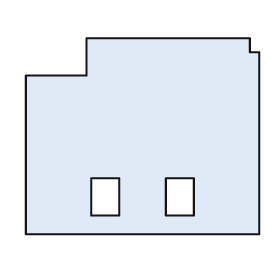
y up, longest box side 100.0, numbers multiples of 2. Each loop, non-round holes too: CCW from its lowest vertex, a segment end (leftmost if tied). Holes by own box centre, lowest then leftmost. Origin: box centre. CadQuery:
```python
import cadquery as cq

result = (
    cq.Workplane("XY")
    .moveTo(-50.0, -42.0)
    .lineTo(50.0, -42.0)
    .lineTo(50.0, 36.0)
    .lineTo(46.0, 36.0)
    .lineTo(46.0, 42.0)
    .lineTo(-24.0, 42.0)
    .lineTo(-24.0, 26.0)
    .lineTo(-50.0, 26.0)
    .close()
    .moveTo(-22.0, -34.0)
    .lineTo(-10.0, -34.0)
    .lineTo(-10.0, -18.0)
    .lineTo(-22.0, -18.0)
    .close()
    .moveTo(10.0, -34.0)
    .lineTo(22.0, -34.0)
    .lineTo(22.0, -18.0)
    .lineTo(10.0, -18.0)
    .close()
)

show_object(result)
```